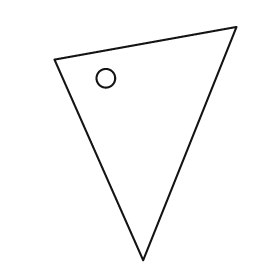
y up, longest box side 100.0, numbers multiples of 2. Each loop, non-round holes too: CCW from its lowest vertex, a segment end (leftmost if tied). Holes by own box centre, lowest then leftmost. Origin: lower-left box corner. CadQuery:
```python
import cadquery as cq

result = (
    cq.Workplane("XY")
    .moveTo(38.0, 0.0)
    .lineTo(78.0, 100.0)
    .lineTo(0.0, 86.0)
    .close()
    .moveTo(22.0, 78.0)
    .circle(4.0)
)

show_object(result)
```